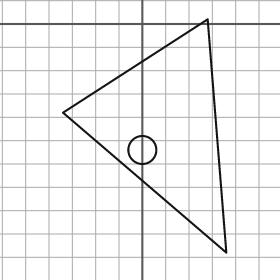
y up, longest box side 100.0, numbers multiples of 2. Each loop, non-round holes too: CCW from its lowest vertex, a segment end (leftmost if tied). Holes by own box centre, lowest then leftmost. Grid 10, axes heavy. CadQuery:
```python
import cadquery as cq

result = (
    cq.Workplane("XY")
    .moveTo(36.0, -98.0)
    .lineTo(28.0, 2.0)
    .lineTo(-34.0, -38.0)
    .close()
    .moveTo(0.0, -54.0)
    .circle(6.0)
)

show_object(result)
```